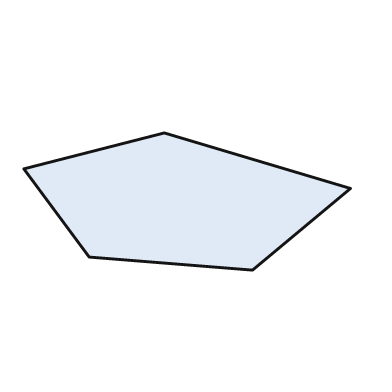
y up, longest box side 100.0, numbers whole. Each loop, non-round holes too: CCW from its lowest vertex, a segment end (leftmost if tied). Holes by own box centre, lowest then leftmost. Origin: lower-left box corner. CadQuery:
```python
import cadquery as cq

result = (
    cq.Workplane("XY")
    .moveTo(70.0, 0.0)
    .lineTo(100.0, 25.0)
    .lineTo(43.0, 42.0)
    .lineTo(0.0, 31.0)
    .lineTo(20.0, 4.0)
    .close()
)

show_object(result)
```